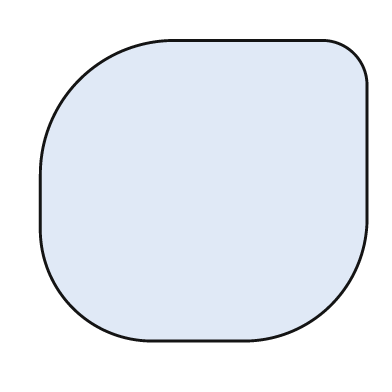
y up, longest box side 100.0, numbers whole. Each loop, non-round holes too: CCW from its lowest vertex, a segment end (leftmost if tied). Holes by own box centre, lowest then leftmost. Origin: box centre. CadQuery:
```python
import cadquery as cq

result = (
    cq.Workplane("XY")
    .moveTo(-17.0, -46.0)
    .lineTo(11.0, -46.0)
    .threePointArc((39.0, -35.0), (50.0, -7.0))
    .lineTo(50.0, 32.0)
    .threePointArc((46.0, 42.0), (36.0, 46.0))
    .lineTo(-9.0, 46.0)
    .threePointArc((-38.0, 34.0), (-50.0, 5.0))
    .lineTo(-50.0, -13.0)
    .threePointArc((-40.0, -36.0), (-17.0, -46.0))
    .close()
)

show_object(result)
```